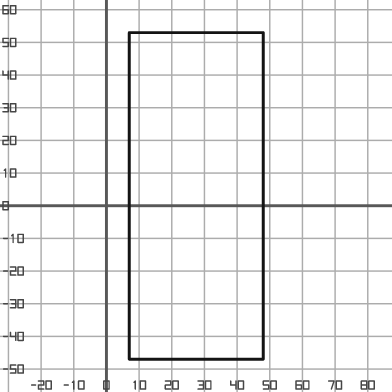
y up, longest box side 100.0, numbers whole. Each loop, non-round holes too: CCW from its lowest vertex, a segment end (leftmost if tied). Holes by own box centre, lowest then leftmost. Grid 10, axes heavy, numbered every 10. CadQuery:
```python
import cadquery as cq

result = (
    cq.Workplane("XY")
    .moveTo(7.0, -47.0)
    .lineTo(48.0, -47.0)
    .lineTo(48.0, 53.0)
    .lineTo(7.0, 53.0)
    .close()
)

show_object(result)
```